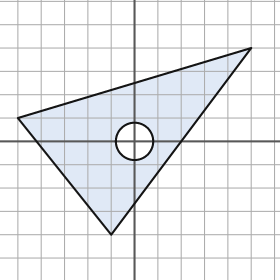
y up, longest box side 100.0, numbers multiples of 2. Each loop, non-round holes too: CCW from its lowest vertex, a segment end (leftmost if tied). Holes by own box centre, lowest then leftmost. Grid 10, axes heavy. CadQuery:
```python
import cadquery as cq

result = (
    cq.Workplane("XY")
    .moveTo(-10.0, -40.0)
    .lineTo(50.0, 40.0)
    .lineTo(-50.0, 10.0)
    .close()
    .moveTo(0.0, 0.0)
    .circle(8.0)
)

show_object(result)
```